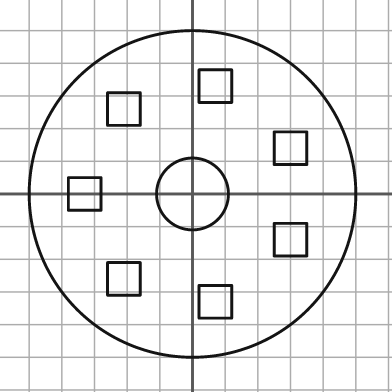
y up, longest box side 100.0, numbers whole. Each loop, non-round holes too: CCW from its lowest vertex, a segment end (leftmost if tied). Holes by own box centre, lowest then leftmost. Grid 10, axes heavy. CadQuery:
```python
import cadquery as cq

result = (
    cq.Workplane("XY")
    .moveTo(0.0, 0.0)
    .circle(50.0)
    .moveTo(2.0, -38.0)
    .lineTo(12.0, -38.0)
    .lineTo(12.0, -28.0)
    .lineTo(2.0, -28.0)
    .close()
    .moveTo(-26.0, -31.0)
    .lineTo(-16.0, -31.0)
    .lineTo(-16.0, -21.0)
    .lineTo(-26.0, -21.0)
    .close()
    .moveTo(25.0, -19.0)
    .lineTo(35.0, -19.0)
    .lineTo(35.0, -9.0)
    .lineTo(25.0, -9.0)
    .close()
    .moveTo(-38.0, -5.0)
    .lineTo(-28.0, -5.0)
    .lineTo(-28.0, 5.0)
    .lineTo(-38.0, 5.0)
    .close()
    .moveTo(0.0, 0.0)
    .circle(11.0)
    .moveTo(25.0, 9.0)
    .lineTo(35.0, 9.0)
    .lineTo(35.0, 19.0)
    .lineTo(25.0, 19.0)
    .close()
    .moveTo(-26.0, 21.0)
    .lineTo(-16.0, 21.0)
    .lineTo(-16.0, 31.0)
    .lineTo(-26.0, 31.0)
    .close()
    .moveTo(2.0, 28.0)
    .lineTo(12.0, 28.0)
    .lineTo(12.0, 38.0)
    .lineTo(2.0, 38.0)
    .close()
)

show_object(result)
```